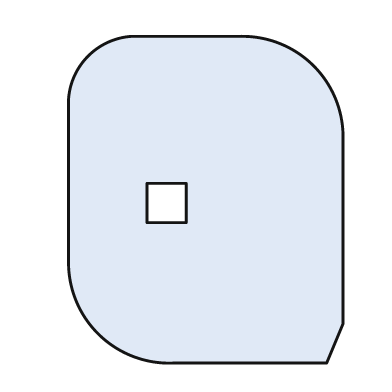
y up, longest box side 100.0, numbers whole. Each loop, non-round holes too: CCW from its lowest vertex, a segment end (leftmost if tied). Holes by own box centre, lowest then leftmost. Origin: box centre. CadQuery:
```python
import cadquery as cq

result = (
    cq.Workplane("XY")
    .moveTo(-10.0, -50.0)
    .lineTo(37.0, -50.0)
    .lineTo(42.0, -38.0)
    .lineTo(42.0, 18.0)
    .threePointArc((33.0, 41.0), (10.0, 50.0))
    .lineTo(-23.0, 50.0)
    .threePointArc((-36.0, 44.0), (-42.0, 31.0))
    .lineTo(-42.0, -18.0)
    .threePointArc((-33.0, -41.0), (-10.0, -50.0))
    .close()
    .moveTo(-18.0, -7.0)
    .lineTo(-6.0, -7.0)
    .lineTo(-6.0, 5.0)
    .lineTo(-18.0, 5.0)
    .close()
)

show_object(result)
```